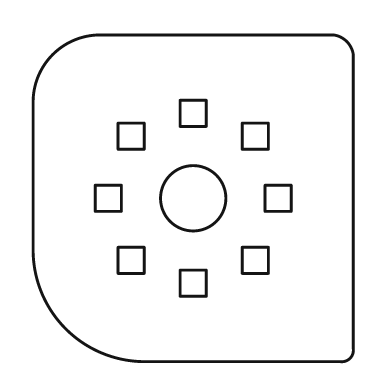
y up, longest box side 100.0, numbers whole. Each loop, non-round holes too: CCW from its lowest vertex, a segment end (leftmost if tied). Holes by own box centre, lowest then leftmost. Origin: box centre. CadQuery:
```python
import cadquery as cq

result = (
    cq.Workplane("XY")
    .moveTo(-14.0, -50.0)
    .lineTo(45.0, -50.0)
    .threePointArc((48.0, -49.0), (49.0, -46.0))
    .lineTo(49.0, 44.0)
    .threePointArc((47.0, 48.0), (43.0, 50.0))
    .lineTo(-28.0, 50.0)
    .threePointArc((-43.0, 44.0), (-49.0, 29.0))
    .lineTo(-49.0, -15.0)
    .threePointArc((-39.0, -40.0), (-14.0, -50.0))
    .close()
    .moveTo(-4.0, -30.0)
    .lineTo(4.0, -30.0)
    .lineTo(4.0, -22.0)
    .lineTo(-4.0, -22.0)
    .close()
    .moveTo(-23.0, -23.0)
    .lineTo(-15.0, -23.0)
    .lineTo(-15.0, -15.0)
    .lineTo(-23.0, -15.0)
    .close()
    .moveTo(15.0, -23.0)
    .lineTo(23.0, -23.0)
    .lineTo(23.0, -15.0)
    .lineTo(15.0, -15.0)
    .close()
    .moveTo(-30.0, -4.0)
    .lineTo(-22.0, -4.0)
    .lineTo(-22.0, 4.0)
    .lineTo(-30.0, 4.0)
    .close()
    .moveTo(0.0, 0.0)
    .circle(10.0)
    .moveTo(22.0, -4.0)
    .lineTo(30.0, -4.0)
    .lineTo(30.0, 4.0)
    .lineTo(22.0, 4.0)
    .close()
    .moveTo(-23.0, 15.0)
    .lineTo(-15.0, 15.0)
    .lineTo(-15.0, 23.0)
    .lineTo(-23.0, 23.0)
    .close()
    .moveTo(15.0, 15.0)
    .lineTo(23.0, 15.0)
    .lineTo(23.0, 23.0)
    .lineTo(15.0, 23.0)
    .close()
    .moveTo(-4.0, 22.0)
    .lineTo(4.0, 22.0)
    .lineTo(4.0, 30.0)
    .lineTo(-4.0, 30.0)
    .close()
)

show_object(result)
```